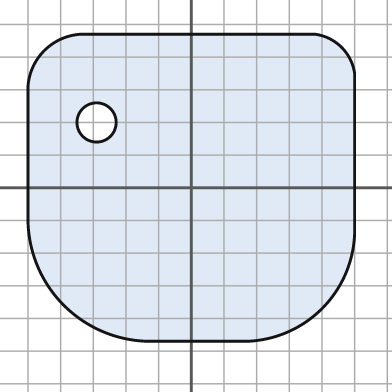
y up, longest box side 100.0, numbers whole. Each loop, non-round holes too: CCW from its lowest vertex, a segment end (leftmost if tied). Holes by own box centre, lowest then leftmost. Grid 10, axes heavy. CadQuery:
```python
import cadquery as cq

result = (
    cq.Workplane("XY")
    .moveTo(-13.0, -47.0)
    .lineTo(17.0, -47.0)
    .threePointArc((40.0, -37.0), (50.0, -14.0))
    .lineTo(50.0, 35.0)
    .threePointArc((46.0, 43.0), (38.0, 47.0))
    .lineTo(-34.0, 47.0)
    .threePointArc((-45.0, 42.0), (-50.0, 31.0))
    .lineTo(-50.0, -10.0)
    .threePointArc((-39.0, -36.0), (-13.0, -47.0))
    .close()
    .moveTo(-29.0, 20.0)
    .circle(6.0)
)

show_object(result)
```